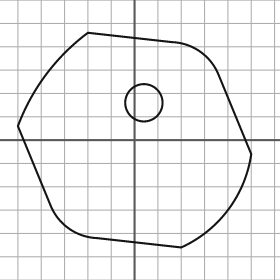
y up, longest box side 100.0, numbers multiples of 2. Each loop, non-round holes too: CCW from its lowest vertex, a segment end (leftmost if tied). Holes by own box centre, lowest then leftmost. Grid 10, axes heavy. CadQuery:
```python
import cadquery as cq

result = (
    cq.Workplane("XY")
    .moveTo(20.0, -46.0)
    .threePointArc((40.0, -30.0), (50.0, -6.0))
    .lineTo(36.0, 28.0)
    .threePointArc((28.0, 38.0), (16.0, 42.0))
    .lineTo(-20.0, 46.0)
    .threePointArc((-38.0, 28.0), (-50.0, 6.0))
    .lineTo(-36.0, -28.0)
    .threePointArc((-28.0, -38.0), (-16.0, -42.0))
    .close()
    .moveTo(4.0, 16.0)
    .circle(8.0)
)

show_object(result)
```